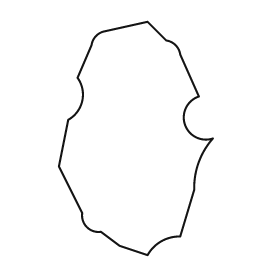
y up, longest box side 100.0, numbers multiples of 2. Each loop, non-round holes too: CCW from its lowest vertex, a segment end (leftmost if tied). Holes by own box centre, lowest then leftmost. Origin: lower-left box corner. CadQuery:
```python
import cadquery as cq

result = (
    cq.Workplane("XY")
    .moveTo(38.0, 0.0)
    .threePointArc((44.0, 6.0), (52.0, 8.0))
    .lineTo(58.0, 28.0)
    .threePointArc((60.0, 40.0), (66.0, 50.0))
    .threePointArc((54.0, 56.0), (60.0, 68.0))
    .lineTo(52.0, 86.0)
    .threePointArc((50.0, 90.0), (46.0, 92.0))
    .lineTo(38.0, 100.0)
    .lineTo(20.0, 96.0)
    .threePointArc((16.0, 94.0), (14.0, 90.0))
    .lineTo(8.0, 76.0)
    .threePointArc((10.0, 66.0), (4.0, 58.0))
    .lineTo(0.0, 38.0)
    .lineTo(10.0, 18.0)
    .threePointArc((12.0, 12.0), (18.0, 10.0))
    .lineTo(26.0, 4.0)
    .close()
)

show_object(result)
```